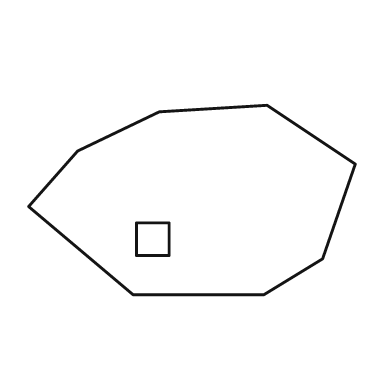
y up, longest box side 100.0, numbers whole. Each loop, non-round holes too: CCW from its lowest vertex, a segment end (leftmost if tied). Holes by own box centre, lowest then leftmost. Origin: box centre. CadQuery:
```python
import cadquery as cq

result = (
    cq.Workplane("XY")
    .moveTo(-18.0, -29.0)
    .lineTo(22.0, -29.0)
    .lineTo(40.0, -18.0)
    .lineTo(50.0, 11.0)
    .lineTo(23.0, 29.0)
    .lineTo(-10.0, 27.0)
    .lineTo(-35.0, 15.0)
    .lineTo(-50.0, -2.0)
    .close()
    .moveTo(-17.0, -17.0)
    .lineTo(-7.0, -17.0)
    .lineTo(-7.0, -7.0)
    .lineTo(-17.0, -7.0)
    .close()
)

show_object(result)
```